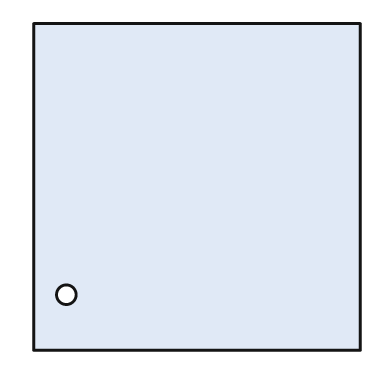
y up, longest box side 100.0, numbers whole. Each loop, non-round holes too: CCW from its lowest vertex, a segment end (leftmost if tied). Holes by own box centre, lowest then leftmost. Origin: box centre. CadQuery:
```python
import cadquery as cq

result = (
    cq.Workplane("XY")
    .moveTo(-50.0, -50.0)
    .lineTo(50.0, -50.0)
    .lineTo(50.0, 50.0)
    .lineTo(-50.0, 50.0)
    .close()
    .moveTo(-40.0, -33.0)
    .circle(3.0)
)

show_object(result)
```